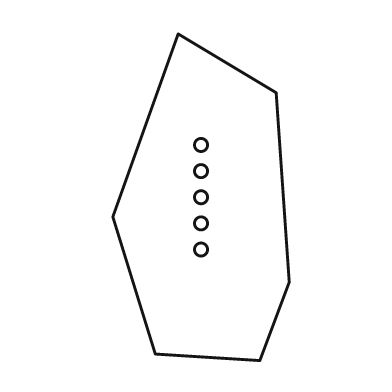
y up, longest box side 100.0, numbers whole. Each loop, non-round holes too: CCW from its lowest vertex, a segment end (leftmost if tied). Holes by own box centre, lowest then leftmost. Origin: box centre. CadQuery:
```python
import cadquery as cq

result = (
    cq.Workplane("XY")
    .moveTo(18.0, -50.0)
    .lineTo(27.0, -26.0)
    .lineTo(23.0, 32.0)
    .lineTo(-7.0, 50.0)
    .lineTo(-27.0, -6.0)
    .lineTo(-14.0, -48.0)
    .close()
    .moveTo(0.0, -16.0)
    .circle(2.0)
    .moveTo(0.0, -8.0)
    .circle(2.0)
    .moveTo(0.0, 0.0)
    .circle(2.0)
    .moveTo(0.0, 8.0)
    .circle(2.0)
    .moveTo(0.0, 16.0)
    .circle(2.0)
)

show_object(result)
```